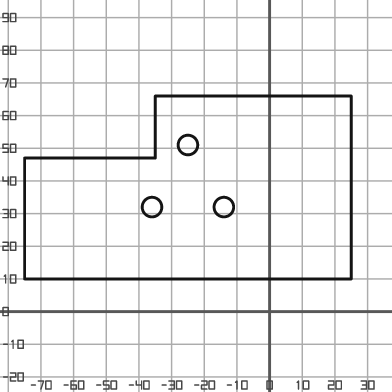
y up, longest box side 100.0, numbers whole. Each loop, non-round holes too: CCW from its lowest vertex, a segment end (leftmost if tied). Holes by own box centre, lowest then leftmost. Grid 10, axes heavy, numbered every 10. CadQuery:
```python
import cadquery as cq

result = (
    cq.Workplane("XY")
    .moveTo(-75.0, 10.0)
    .lineTo(25.0, 10.0)
    .lineTo(25.0, 66.0)
    .lineTo(-35.0, 66.0)
    .lineTo(-35.0, 47.0)
    .lineTo(-75.0, 47.0)
    .close()
    .moveTo(-36.0, 32.0)
    .circle(3.0)
    .moveTo(-14.0, 32.0)
    .circle(3.0)
    .moveTo(-25.0, 51.0)
    .circle(3.0)
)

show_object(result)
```